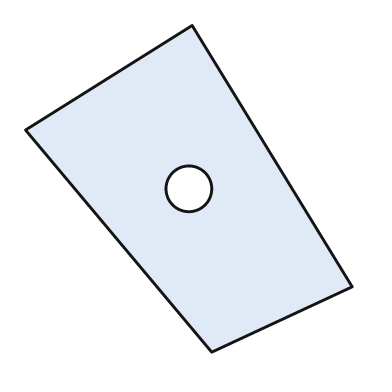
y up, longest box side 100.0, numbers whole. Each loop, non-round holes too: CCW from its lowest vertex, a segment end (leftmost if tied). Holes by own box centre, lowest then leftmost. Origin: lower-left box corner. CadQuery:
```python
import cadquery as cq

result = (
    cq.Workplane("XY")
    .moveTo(57.0, 0.0)
    .lineTo(100.0, 20.0)
    .lineTo(51.0, 100.0)
    .lineTo(0.0, 68.0)
    .close()
    .moveTo(50.0, 50.0)
    .circle(7.0)
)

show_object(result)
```